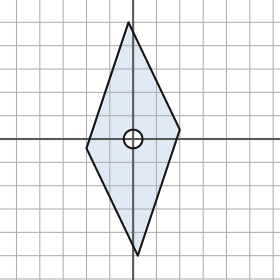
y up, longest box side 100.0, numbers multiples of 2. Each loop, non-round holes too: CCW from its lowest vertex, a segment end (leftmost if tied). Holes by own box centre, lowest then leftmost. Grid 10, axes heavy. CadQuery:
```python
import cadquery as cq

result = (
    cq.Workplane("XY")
    .moveTo(2.0, -50.0)
    .lineTo(20.0, 4.0)
    .lineTo(-2.0, 50.0)
    .lineTo(-20.0, -4.0)
    .close()
    .moveTo(0.0, 0.0)
    .circle(4.0)
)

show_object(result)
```